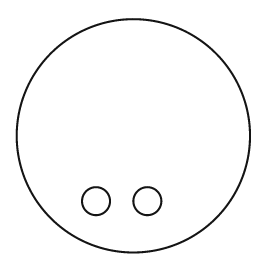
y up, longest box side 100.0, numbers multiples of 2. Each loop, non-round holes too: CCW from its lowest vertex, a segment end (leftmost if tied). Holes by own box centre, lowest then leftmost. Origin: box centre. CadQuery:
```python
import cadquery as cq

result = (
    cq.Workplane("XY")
    .moveTo(0.0, 0.0)
    .circle(50.0)
    .moveTo(-16.0, -28.0)
    .circle(6.0)
    .moveTo(6.0, -28.0)
    .circle(6.0)
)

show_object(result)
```